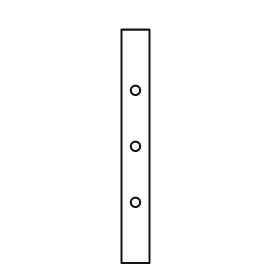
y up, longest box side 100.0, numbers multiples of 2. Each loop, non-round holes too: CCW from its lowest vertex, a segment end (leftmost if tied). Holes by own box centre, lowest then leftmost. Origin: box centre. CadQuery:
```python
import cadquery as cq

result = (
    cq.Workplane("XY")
    .moveTo(-6.0, -50.0)
    .lineTo(6.0, -50.0)
    .lineTo(6.0, 50.0)
    .lineTo(-6.0, 50.0)
    .close()
    .moveTo(0.0, -24.0)
    .circle(2.0)
    .moveTo(0.0, 0.0)
    .circle(2.0)
    .moveTo(0.0, 24.0)
    .circle(2.0)
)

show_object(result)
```